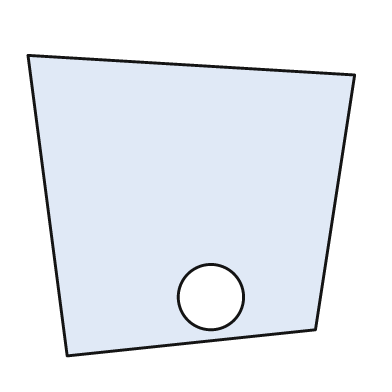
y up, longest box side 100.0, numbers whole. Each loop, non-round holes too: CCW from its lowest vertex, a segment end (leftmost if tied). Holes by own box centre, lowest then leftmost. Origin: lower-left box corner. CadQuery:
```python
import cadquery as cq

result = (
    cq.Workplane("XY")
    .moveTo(12.0, 0.0)
    .lineTo(88.0, 8.0)
    .lineTo(100.0, 86.0)
    .lineTo(0.0, 92.0)
    .close()
    .moveTo(56.0, 18.0)
    .circle(10.0)
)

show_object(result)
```